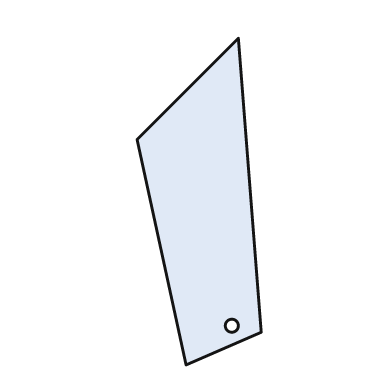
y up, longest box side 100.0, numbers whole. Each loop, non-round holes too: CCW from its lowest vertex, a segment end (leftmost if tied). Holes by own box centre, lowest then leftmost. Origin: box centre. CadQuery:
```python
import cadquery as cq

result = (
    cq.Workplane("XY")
    .moveTo(-4.0, -50.0)
    .lineTo(19.0, -40.0)
    .lineTo(12.0, 50.0)
    .lineTo(-19.0, 19.0)
    .close()
    .moveTo(10.0, -38.0)
    .circle(2.0)
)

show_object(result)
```